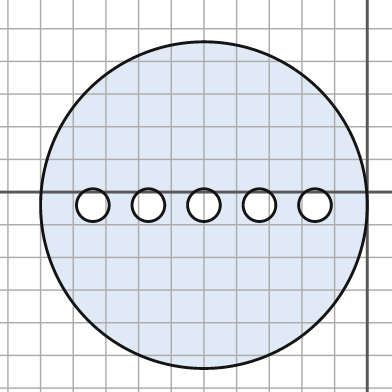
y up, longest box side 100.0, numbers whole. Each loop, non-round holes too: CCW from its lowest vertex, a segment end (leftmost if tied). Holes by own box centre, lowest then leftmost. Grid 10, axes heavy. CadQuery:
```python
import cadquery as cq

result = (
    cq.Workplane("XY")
    .moveTo(-50.0, -4.0)
    .circle(50.0)
    .moveTo(-84.0, -4.0)
    .circle(5.0)
    .moveTo(-67.0, -4.0)
    .circle(5.0)
    .moveTo(-50.0, -4.0)
    .circle(5.0)
    .moveTo(-33.0, -4.0)
    .circle(5.0)
    .moveTo(-16.0, -4.0)
    .circle(5.0)
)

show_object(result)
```